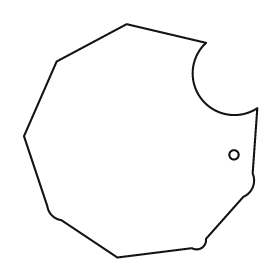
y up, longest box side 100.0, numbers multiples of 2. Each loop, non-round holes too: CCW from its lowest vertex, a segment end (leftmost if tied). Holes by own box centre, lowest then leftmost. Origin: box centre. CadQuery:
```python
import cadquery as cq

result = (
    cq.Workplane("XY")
    .moveTo(-10.0, -50.0)
    .lineTo(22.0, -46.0)
    .threePointArc((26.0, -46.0), (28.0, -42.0))
    .lineTo(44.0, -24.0)
    .threePointArc((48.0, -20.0), (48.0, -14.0))
    .lineTo(50.0, 14.0)
    .threePointArc((26.0, 18.0), (28.0, 42.0))
    .lineTo(-6.0, 50.0)
    .lineTo(-36.0, 34.0)
    .lineTo(-50.0, 2.0)
    .lineTo(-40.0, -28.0)
    .threePointArc((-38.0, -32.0), (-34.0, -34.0))
    .close()
    .moveTo(40.0, -6.0)
    .circle(2.0)
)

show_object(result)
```